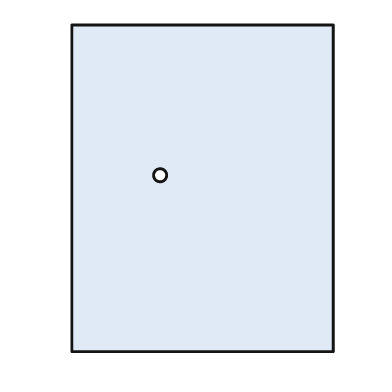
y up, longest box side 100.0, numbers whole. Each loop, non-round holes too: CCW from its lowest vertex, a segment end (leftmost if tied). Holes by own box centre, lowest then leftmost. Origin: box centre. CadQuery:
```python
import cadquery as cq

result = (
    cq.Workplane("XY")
    .moveTo(-40.0, -50.0)
    .lineTo(40.0, -50.0)
    .lineTo(40.0, 50.0)
    .lineTo(-40.0, 50.0)
    .close()
    .moveTo(-13.0, 4.0)
    .circle(2.0)
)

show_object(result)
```